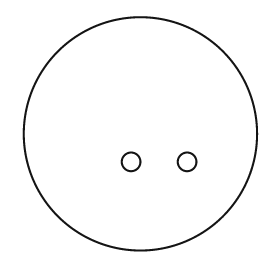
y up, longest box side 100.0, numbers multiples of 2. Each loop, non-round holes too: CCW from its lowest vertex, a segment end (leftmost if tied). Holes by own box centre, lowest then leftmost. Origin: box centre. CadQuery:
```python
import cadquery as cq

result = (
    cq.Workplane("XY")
    .moveTo(0.0, 0.0)
    .circle(50.0)
    .moveTo(-4.0, -12.0)
    .circle(4.0)
    .moveTo(20.0, -12.0)
    .circle(4.0)
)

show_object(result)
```